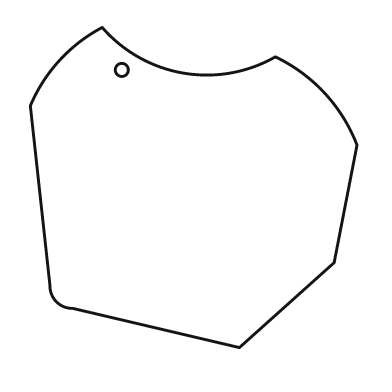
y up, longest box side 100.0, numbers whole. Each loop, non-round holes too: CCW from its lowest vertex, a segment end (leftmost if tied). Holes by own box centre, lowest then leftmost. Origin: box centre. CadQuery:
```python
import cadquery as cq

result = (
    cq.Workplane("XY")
    .moveTo(14.0, -49.0)
    .lineTo(43.0, -23.0)
    .lineTo(50.0, 13.0)
    .threePointArc((40.0, 29.0), (25.0, 40.0))
    .threePointArc((-3.0, 35.0), (-28.0, 49.0))
    .threePointArc((-41.0, 39.0), (-50.0, 25.0))
    .lineTo(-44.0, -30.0)
    .threePointArc((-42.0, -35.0), (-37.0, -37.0))
    .close()
    .moveTo(-22.0, 36.0)
    .circle(2.0)
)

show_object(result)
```